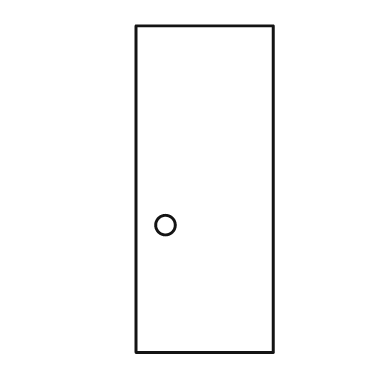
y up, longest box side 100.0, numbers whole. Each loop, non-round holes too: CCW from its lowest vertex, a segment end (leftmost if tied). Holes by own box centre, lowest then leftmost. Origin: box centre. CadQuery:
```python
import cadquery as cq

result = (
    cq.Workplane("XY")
    .moveTo(-21.0, -50.0)
    .lineTo(21.0, -50.0)
    .lineTo(21.0, 50.0)
    .lineTo(-21.0, 50.0)
    .close()
    .moveTo(-12.0, -11.0)
    .circle(3.0)
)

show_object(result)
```